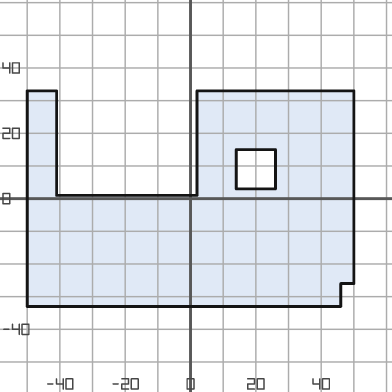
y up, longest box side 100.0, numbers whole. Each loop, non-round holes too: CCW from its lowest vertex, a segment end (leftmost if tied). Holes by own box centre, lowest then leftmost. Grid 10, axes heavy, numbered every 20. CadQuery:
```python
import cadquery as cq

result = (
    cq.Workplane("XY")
    .moveTo(-50.0, -33.0)
    .lineTo(46.0, -33.0)
    .lineTo(46.0, -26.0)
    .lineTo(50.0, -26.0)
    .lineTo(50.0, 33.0)
    .lineTo(2.0, 33.0)
    .lineTo(2.0, 1.0)
    .lineTo(-41.0, 1.0)
    .lineTo(-41.0, 33.0)
    .lineTo(-50.0, 33.0)
    .close()
    .moveTo(14.0, 3.0)
    .lineTo(26.0, 3.0)
    .lineTo(26.0, 15.0)
    .lineTo(14.0, 15.0)
    .close()
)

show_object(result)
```